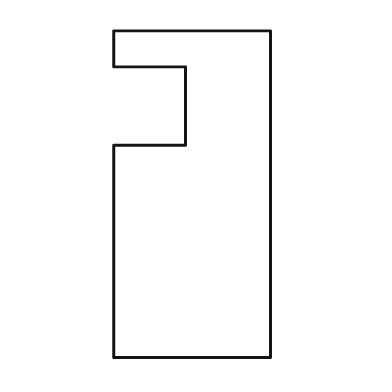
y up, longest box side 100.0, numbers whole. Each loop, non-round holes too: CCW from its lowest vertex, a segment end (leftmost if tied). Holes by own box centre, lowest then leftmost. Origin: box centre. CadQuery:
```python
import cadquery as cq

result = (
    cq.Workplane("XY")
    .moveTo(-24.0, -50.0)
    .lineTo(24.0, -50.0)
    .lineTo(24.0, 50.0)
    .lineTo(-24.0, 50.0)
    .lineTo(-24.0, 39.0)
    .lineTo(-2.0, 39.0)
    .lineTo(-2.0, 15.0)
    .lineTo(-24.0, 15.0)
    .close()
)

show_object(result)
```